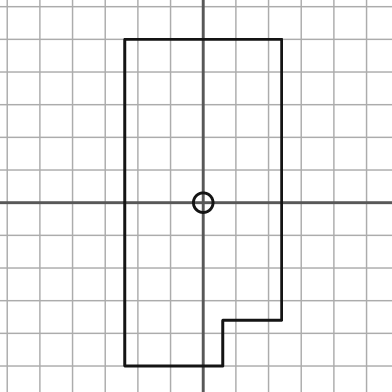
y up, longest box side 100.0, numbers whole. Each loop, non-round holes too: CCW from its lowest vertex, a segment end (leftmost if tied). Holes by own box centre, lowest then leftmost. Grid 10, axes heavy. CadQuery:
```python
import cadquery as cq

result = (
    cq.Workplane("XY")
    .moveTo(-24.0, -50.0)
    .lineTo(6.0, -50.0)
    .lineTo(6.0, -36.0)
    .lineTo(24.0, -36.0)
    .lineTo(24.0, 50.0)
    .lineTo(-24.0, 50.0)
    .close()
    .moveTo(0.0, 0.0)
    .circle(3.0)
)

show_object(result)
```